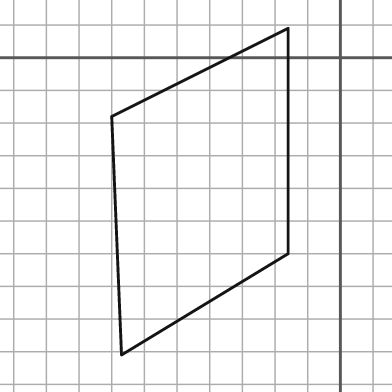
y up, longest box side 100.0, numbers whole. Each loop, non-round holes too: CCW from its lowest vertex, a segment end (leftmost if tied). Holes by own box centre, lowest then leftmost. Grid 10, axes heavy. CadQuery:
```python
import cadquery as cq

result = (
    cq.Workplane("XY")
    .moveTo(-67.0, -91.0)
    .lineTo(-16.0, -60.0)
    .lineTo(-16.0, 9.0)
    .lineTo(-70.0, -18.0)
    .close()
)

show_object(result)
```